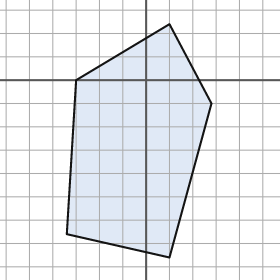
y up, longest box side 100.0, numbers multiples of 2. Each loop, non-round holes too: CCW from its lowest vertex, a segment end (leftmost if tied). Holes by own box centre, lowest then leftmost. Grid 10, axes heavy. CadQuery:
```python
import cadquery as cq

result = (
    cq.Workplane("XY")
    .moveTo(10.0, -76.0)
    .lineTo(28.0, -10.0)
    .lineTo(10.0, 24.0)
    .lineTo(-30.0, 0.0)
    .lineTo(-34.0, -66.0)
    .close()
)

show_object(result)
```